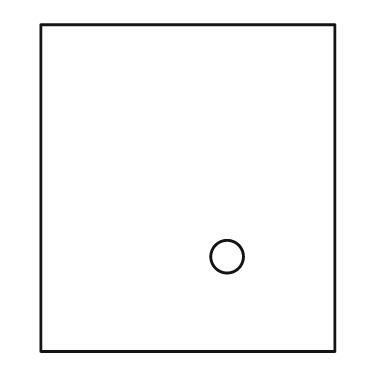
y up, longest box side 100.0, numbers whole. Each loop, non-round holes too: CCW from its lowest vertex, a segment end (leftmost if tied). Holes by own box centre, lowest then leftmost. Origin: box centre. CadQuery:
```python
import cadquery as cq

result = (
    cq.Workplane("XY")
    .moveTo(-45.0, -50.0)
    .lineTo(45.0, -50.0)
    .lineTo(45.0, 50.0)
    .lineTo(-45.0, 50.0)
    .close()
    .moveTo(12.0, -21.0)
    .circle(5.0)
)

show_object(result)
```